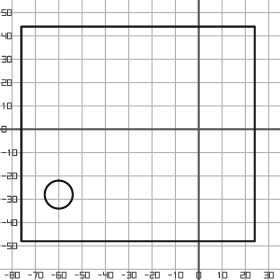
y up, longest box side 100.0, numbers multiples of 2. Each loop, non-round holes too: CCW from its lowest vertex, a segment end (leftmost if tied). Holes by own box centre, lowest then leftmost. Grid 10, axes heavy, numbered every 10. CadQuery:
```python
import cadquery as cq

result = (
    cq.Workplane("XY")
    .moveTo(-76.0, -48.0)
    .lineTo(24.0, -48.0)
    .lineTo(24.0, 44.0)
    .lineTo(-76.0, 44.0)
    .close()
    .moveTo(-60.0, -28.0)
    .circle(6.0)
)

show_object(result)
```